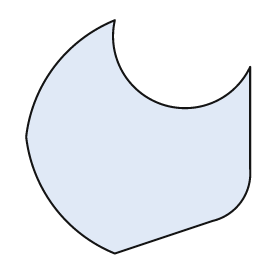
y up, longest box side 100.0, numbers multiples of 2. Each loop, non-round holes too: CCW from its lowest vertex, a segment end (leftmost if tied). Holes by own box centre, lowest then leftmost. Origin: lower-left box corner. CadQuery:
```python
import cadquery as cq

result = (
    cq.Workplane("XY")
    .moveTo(38.0, 0.0)
    .lineTo(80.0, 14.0)
    .threePointArc((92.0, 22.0), (96.0, 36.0))
    .lineTo(96.0, 80.0)
    .threePointArc((58.0, 64.0), (38.0, 100.0))
    .threePointArc((12.0, 80.0), (0.0, 50.0))
    .threePointArc((12.0, 20.0), (38.0, 0.0))
    .close()
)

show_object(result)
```